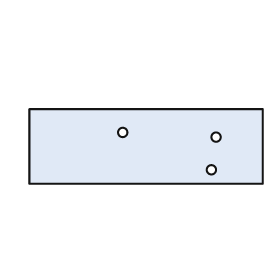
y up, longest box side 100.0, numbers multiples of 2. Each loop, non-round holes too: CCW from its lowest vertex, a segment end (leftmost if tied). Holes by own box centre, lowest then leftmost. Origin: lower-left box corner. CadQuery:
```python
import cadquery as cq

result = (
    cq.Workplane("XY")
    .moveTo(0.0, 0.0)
    .lineTo(100.0, 0.0)
    .lineTo(100.0, 32.0)
    .lineTo(0.0, 32.0)
    .close()
    .moveTo(78.0, 6.0)
    .circle(2.0)
    .moveTo(80.0, 20.0)
    .circle(2.0)
    .moveTo(40.0, 22.0)
    .circle(2.0)
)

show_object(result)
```